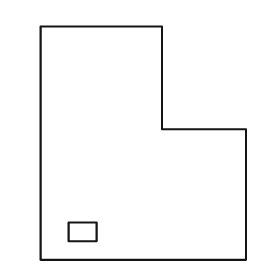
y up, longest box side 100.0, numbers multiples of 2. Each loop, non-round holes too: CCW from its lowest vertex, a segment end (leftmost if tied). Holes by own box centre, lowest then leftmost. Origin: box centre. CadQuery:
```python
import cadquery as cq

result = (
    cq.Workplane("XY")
    .moveTo(-44.0, -50.0)
    .lineTo(44.0, -50.0)
    .lineTo(44.0, 6.0)
    .lineTo(8.0, 6.0)
    .lineTo(8.0, 50.0)
    .lineTo(-44.0, 50.0)
    .close()
    .moveTo(-32.0, -42.0)
    .lineTo(-20.0, -42.0)
    .lineTo(-20.0, -34.0)
    .lineTo(-32.0, -34.0)
    .close()
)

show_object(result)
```